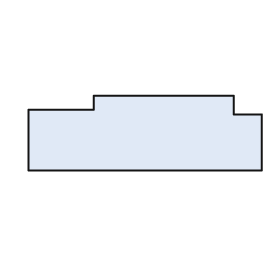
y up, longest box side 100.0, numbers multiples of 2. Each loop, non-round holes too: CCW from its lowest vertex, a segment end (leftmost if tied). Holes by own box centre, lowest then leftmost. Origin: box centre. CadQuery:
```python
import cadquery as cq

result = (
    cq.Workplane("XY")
    .moveTo(-50.0, -16.0)
    .lineTo(50.0, -16.0)
    .lineTo(50.0, 8.0)
    .lineTo(38.0, 8.0)
    .lineTo(38.0, 16.0)
    .lineTo(-22.0, 16.0)
    .lineTo(-22.0, 10.0)
    .lineTo(-50.0, 10.0)
    .close()
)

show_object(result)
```